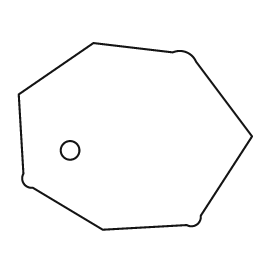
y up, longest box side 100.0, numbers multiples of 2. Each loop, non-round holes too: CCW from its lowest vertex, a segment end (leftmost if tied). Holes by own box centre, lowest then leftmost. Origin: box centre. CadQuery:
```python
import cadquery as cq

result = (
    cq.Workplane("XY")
    .moveTo(-14.0, -40.0)
    .lineTo(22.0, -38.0)
    .threePointArc((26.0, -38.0), (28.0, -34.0))
    .lineTo(50.0, 0.0)
    .lineTo(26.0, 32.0)
    .threePointArc((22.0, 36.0), (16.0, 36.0))
    .lineTo(-18.0, 40.0)
    .lineTo(-50.0, 18.0)
    .lineTo(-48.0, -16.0)
    .threePointArc((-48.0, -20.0), (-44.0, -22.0))
    .close()
    .moveTo(-28.0, -6.0)
    .circle(4.0)
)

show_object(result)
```